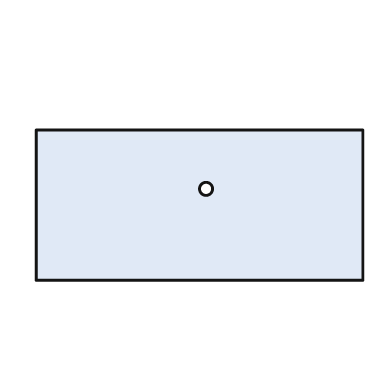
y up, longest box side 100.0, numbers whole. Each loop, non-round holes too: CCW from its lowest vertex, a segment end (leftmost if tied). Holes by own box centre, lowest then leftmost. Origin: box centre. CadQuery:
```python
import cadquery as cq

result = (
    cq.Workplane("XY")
    .moveTo(-50.0, -23.0)
    .lineTo(50.0, -23.0)
    .lineTo(50.0, 23.0)
    .lineTo(-50.0, 23.0)
    .close()
    .moveTo(2.0, 5.0)
    .circle(2.0)
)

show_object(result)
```